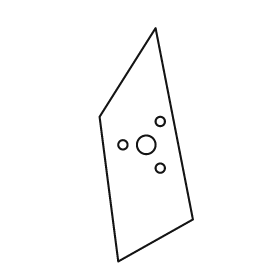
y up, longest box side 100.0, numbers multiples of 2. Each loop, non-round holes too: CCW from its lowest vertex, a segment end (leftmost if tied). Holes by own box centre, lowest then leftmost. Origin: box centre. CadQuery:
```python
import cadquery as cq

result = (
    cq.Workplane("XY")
    .moveTo(-12.0, -50.0)
    .lineTo(20.0, -32.0)
    .lineTo(4.0, 50.0)
    .lineTo(-20.0, 12.0)
    .close()
    .moveTo(6.0, -10.0)
    .circle(2.0)
    .moveTo(-10.0, 0.0)
    .circle(2.0)
    .moveTo(0.0, 0.0)
    .circle(4.0)
    .moveTo(6.0, 10.0)
    .circle(2.0)
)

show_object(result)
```